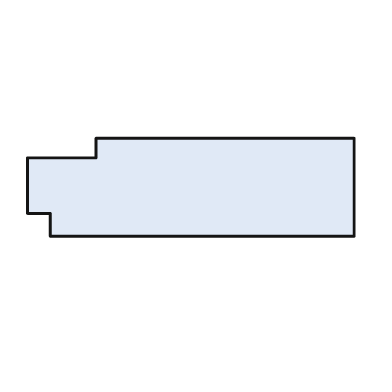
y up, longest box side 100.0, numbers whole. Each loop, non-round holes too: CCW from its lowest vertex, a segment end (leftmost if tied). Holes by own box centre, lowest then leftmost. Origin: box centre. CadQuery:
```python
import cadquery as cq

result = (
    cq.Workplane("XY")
    .moveTo(-43.0, -15.0)
    .lineTo(50.0, -15.0)
    .lineTo(50.0, 15.0)
    .lineTo(-29.0, 15.0)
    .lineTo(-29.0, 9.0)
    .lineTo(-50.0, 9.0)
    .lineTo(-50.0, -8.0)
    .lineTo(-43.0, -8.0)
    .close()
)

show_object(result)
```